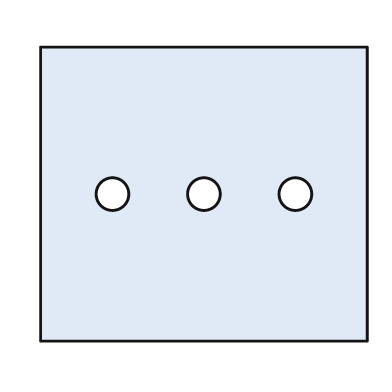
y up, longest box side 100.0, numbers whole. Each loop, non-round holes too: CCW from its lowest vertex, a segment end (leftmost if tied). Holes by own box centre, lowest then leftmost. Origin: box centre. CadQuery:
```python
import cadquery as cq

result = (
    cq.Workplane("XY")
    .moveTo(-50.0, -45.0)
    .lineTo(50.0, -45.0)
    .lineTo(50.0, 45.0)
    .lineTo(-50.0, 45.0)
    .close()
    .moveTo(-28.0, 0.0)
    .circle(5.0)
    .moveTo(0.0, 0.0)
    .circle(5.0)
    .moveTo(28.0, 0.0)
    .circle(5.0)
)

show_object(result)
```